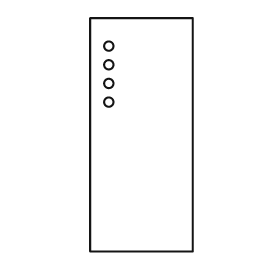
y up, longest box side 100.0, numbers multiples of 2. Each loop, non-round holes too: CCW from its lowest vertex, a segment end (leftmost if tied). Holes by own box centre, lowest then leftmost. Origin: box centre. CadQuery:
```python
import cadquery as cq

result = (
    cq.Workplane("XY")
    .moveTo(-22.0, -50.0)
    .lineTo(22.0, -50.0)
    .lineTo(22.0, 50.0)
    .lineTo(-22.0, 50.0)
    .close()
    .moveTo(-14.0, 14.0)
    .circle(2.0)
    .moveTo(-14.0, 22.0)
    .circle(2.0)
    .moveTo(-14.0, 30.0)
    .circle(2.0)
    .moveTo(-14.0, 38.0)
    .circle(2.0)
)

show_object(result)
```